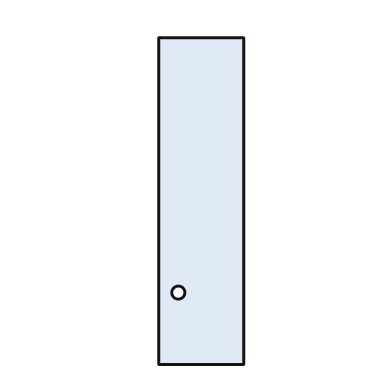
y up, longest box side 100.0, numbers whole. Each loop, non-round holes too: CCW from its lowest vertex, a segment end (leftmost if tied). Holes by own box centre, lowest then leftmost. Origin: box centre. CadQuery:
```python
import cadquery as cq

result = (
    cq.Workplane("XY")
    .moveTo(-13.0, -50.0)
    .lineTo(13.0, -50.0)
    .lineTo(13.0, 50.0)
    .lineTo(-13.0, 50.0)
    .close()
    .moveTo(-7.0, -28.0)
    .circle(2.0)
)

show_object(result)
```